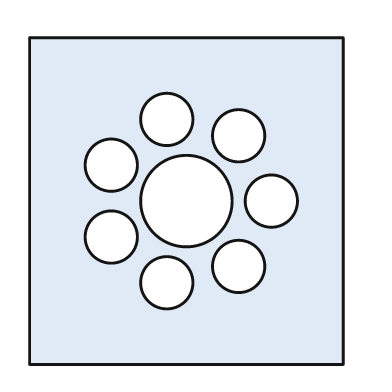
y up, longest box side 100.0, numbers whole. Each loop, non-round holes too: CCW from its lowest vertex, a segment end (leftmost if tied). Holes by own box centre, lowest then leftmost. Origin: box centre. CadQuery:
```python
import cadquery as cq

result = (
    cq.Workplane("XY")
    .moveTo(-48.0, -50.0)
    .lineTo(48.0, -50.0)
    .lineTo(48.0, 50.0)
    .lineTo(-48.0, 50.0)
    .close()
    .moveTo(-6.0, -25.0)
    .circle(8.0)
    .moveTo(16.0, -20.0)
    .circle(8.0)
    .moveTo(-23.0, -11.0)
    .circle(8.0)
    .moveTo(0.0, 0.0)
    .circle(14.0)
    .moveTo(26.0, 0.0)
    .circle(8.0)
    .moveTo(-23.0, 11.0)
    .circle(8.0)
    .moveTo(16.0, 20.0)
    .circle(8.0)
    .moveTo(-6.0, 25.0)
    .circle(8.0)
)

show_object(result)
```